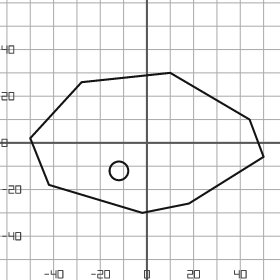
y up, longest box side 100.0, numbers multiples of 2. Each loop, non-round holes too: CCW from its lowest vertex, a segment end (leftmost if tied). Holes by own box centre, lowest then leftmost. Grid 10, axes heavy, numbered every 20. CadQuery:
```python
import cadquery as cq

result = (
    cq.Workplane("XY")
    .moveTo(-2.0, -30.0)
    .lineTo(18.0, -26.0)
    .lineTo(50.0, -6.0)
    .lineTo(44.0, 10.0)
    .lineTo(10.0, 30.0)
    .lineTo(-28.0, 26.0)
    .lineTo(-50.0, 2.0)
    .lineTo(-42.0, -18.0)
    .close()
    .moveTo(-12.0, -12.0)
    .circle(4.0)
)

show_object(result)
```